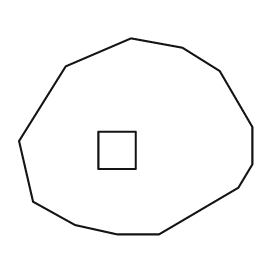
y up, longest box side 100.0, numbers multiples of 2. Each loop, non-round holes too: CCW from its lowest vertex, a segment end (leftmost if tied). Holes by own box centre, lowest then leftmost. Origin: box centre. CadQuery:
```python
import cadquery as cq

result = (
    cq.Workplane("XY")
    .moveTo(-8.0, -42.0)
    .lineTo(10.0, -42.0)
    .lineTo(44.0, -22.0)
    .lineTo(50.0, -12.0)
    .lineTo(50.0, 4.0)
    .lineTo(36.0, 28.0)
    .lineTo(20.0, 38.0)
    .lineTo(-2.0, 42.0)
    .lineTo(-30.0, 30.0)
    .lineTo(-50.0, -2.0)
    .lineTo(-44.0, -28.0)
    .lineTo(-26.0, -38.0)
    .close()
    .moveTo(-16.0, -14.0)
    .lineTo(0.0, -14.0)
    .lineTo(0.0, 2.0)
    .lineTo(-16.0, 2.0)
    .close()
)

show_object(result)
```